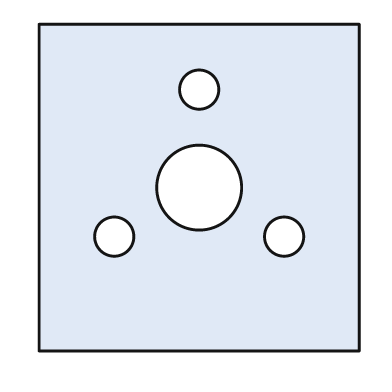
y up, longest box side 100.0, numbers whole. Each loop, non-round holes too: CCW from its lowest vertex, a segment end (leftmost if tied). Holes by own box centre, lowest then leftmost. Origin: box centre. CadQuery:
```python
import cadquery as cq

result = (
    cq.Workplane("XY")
    .moveTo(-49.0, -50.0)
    .lineTo(49.0, -50.0)
    .lineTo(49.0, 50.0)
    .lineTo(-49.0, 50.0)
    .close()
    .moveTo(-26.0, -15.0)
    .circle(6.0)
    .moveTo(26.0, -15.0)
    .circle(6.0)
    .moveTo(0.0, 0.0)
    .circle(13.0)
    .moveTo(0.0, 30.0)
    .circle(6.0)
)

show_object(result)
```